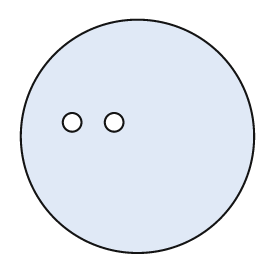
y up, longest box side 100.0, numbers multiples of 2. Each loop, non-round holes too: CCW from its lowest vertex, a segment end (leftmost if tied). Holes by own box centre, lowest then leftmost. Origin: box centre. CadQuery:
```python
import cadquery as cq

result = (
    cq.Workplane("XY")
    .moveTo(0.0, 0.0)
    .circle(50.0)
    .moveTo(-28.0, 6.0)
    .circle(4.0)
    .moveTo(-10.0, 6.0)
    .circle(4.0)
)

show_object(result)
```